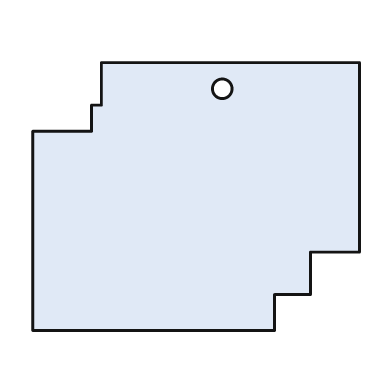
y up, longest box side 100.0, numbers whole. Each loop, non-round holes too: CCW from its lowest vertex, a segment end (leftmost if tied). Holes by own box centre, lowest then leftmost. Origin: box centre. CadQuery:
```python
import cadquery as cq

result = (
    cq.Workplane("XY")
    .moveTo(-50.0, -41.0)
    .lineTo(24.0, -41.0)
    .lineTo(24.0, -30.0)
    .lineTo(35.0, -30.0)
    .lineTo(35.0, -17.0)
    .lineTo(50.0, -17.0)
    .lineTo(50.0, 41.0)
    .lineTo(-29.0, 41.0)
    .lineTo(-29.0, 28.0)
    .lineTo(-32.0, 28.0)
    .lineTo(-32.0, 20.0)
    .lineTo(-50.0, 20.0)
    .close()
    .moveTo(8.0, 33.0)
    .circle(3.0)
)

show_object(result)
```